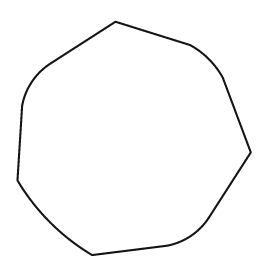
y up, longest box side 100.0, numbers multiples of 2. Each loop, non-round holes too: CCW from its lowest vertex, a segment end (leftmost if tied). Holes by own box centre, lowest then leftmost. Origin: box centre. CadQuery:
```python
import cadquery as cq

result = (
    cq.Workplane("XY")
    .moveTo(-18.0, -50.0)
    .lineTo(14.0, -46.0)
    .threePointArc((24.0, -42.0), (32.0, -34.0))
    .lineTo(50.0, -6.0)
    .lineTo(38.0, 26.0)
    .threePointArc((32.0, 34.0), (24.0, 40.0))
    .lineTo(-8.0, 50.0)
    .lineTo(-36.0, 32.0)
    .threePointArc((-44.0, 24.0), (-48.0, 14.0))
    .lineTo(-50.0, -18.0)
    .threePointArc((-36.0, -36.0), (-18.0, -50.0))
    .close()
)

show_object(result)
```